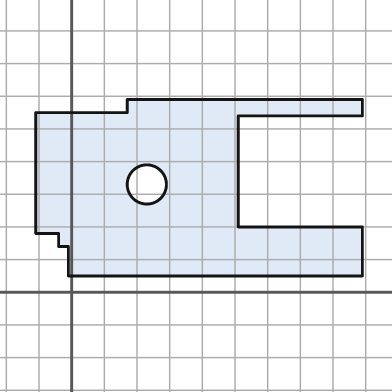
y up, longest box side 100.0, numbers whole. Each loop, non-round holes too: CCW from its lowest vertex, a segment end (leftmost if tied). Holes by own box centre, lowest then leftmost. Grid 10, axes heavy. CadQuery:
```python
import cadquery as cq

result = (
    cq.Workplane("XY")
    .moveTo(-1.0, 5.0)
    .lineTo(89.0, 5.0)
    .lineTo(89.0, 20.0)
    .lineTo(51.0, 20.0)
    .lineTo(51.0, 54.0)
    .lineTo(89.0, 54.0)
    .lineTo(89.0, 59.0)
    .lineTo(17.0, 59.0)
    .lineTo(17.0, 55.0)
    .lineTo(-11.0, 55.0)
    .lineTo(-11.0, 18.0)
    .lineTo(-4.0, 18.0)
    .lineTo(-4.0, 14.0)
    .lineTo(-1.0, 14.0)
    .close()
    .moveTo(23.0, 33.0)
    .circle(6.0)
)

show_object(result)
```